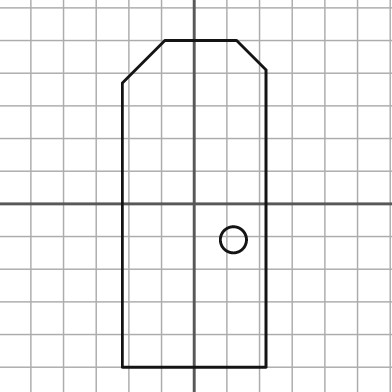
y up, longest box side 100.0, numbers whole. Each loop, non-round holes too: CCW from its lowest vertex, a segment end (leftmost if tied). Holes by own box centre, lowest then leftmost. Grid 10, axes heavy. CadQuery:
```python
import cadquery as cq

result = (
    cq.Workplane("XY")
    .moveTo(-22.0, -50.0)
    .lineTo(22.0, -50.0)
    .lineTo(22.0, 41.0)
    .lineTo(13.0, 50.0)
    .lineTo(-9.0, 50.0)
    .lineTo(-22.0, 37.0)
    .close()
    .moveTo(12.0, -11.0)
    .circle(4.0)
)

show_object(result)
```